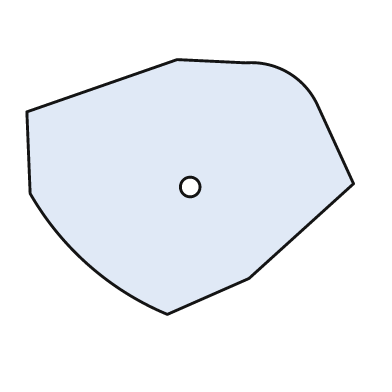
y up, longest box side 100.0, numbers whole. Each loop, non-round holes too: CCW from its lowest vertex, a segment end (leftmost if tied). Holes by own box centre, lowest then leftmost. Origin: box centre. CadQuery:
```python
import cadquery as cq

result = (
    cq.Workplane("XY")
    .moveTo(-7.0, -39.0)
    .lineTo(18.0, -28.0)
    .lineTo(50.0, 1.0)
    .lineTo(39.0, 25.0)
    .threePointArc((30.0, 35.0), (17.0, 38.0))
    .lineTo(-4.0, 39.0)
    .lineTo(-50.0, 23.0)
    .lineTo(-49.0, -2.0)
    .threePointArc((-31.0, -24.0), (-7.0, -39.0))
    .close()
    .moveTo(0.0, 0.0)
    .circle(3.0)
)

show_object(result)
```